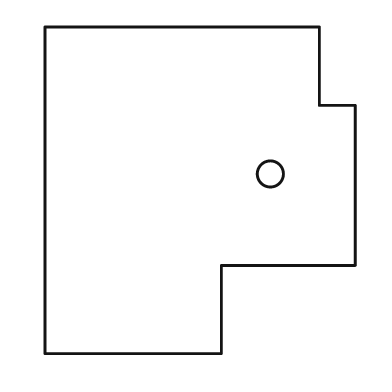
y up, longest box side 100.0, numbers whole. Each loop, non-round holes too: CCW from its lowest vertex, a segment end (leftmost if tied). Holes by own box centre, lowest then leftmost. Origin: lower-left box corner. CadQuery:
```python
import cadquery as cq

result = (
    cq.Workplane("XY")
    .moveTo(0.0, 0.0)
    .lineTo(54.0, 0.0)
    .lineTo(54.0, 27.0)
    .lineTo(95.0, 27.0)
    .lineTo(95.0, 76.0)
    .lineTo(84.0, 76.0)
    .lineTo(84.0, 100.0)
    .lineTo(0.0, 100.0)
    .close()
    .moveTo(69.0, 55.0)
    .circle(4.0)
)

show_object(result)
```